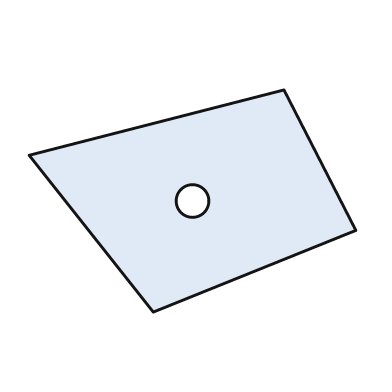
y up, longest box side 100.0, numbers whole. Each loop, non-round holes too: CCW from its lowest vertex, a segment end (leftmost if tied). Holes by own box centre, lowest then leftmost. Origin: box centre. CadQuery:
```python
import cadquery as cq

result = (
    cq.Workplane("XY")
    .moveTo(-12.0, -34.0)
    .lineTo(50.0, -9.0)
    .lineTo(28.0, 34.0)
    .lineTo(-50.0, 14.0)
    .close()
    .moveTo(0.0, 0.0)
    .circle(5.0)
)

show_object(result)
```